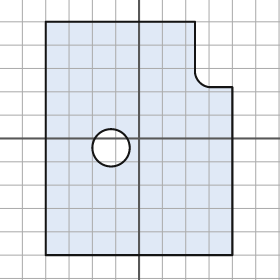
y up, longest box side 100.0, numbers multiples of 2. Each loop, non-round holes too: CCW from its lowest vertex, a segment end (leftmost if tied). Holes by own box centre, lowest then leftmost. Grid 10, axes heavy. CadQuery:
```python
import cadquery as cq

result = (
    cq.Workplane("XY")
    .moveTo(-40.0, -50.0)
    .lineTo(40.0, -50.0)
    .lineTo(40.0, 22.0)
    .lineTo(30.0, 22.0)
    .threePointArc((26.0, 24.0), (24.0, 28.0))
    .lineTo(24.0, 50.0)
    .lineTo(-40.0, 50.0)
    .close()
    .moveTo(-12.0, -4.0)
    .circle(8.0)
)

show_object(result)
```